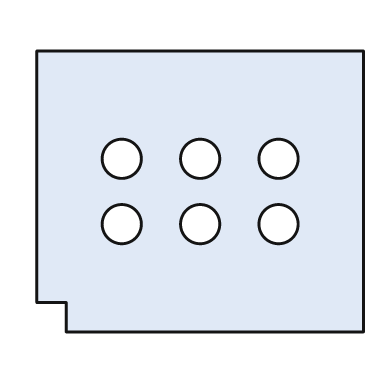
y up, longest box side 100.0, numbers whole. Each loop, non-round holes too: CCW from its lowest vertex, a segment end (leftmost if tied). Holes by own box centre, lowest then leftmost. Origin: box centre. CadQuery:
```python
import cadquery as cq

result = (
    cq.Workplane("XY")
    .moveTo(-41.0, -43.0)
    .lineTo(50.0, -43.0)
    .lineTo(50.0, 43.0)
    .lineTo(-50.0, 43.0)
    .lineTo(-50.0, -34.0)
    .lineTo(-41.0, -34.0)
    .close()
    .moveTo(-24.0, -10.0)
    .circle(6.0)
    .moveTo(0.0, -10.0)
    .circle(6.0)
    .moveTo(24.0, -10.0)
    .circle(6.0)
    .moveTo(-24.0, 10.0)
    .circle(6.0)
    .moveTo(0.0, 10.0)
    .circle(6.0)
    .moveTo(24.0, 10.0)
    .circle(6.0)
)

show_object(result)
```